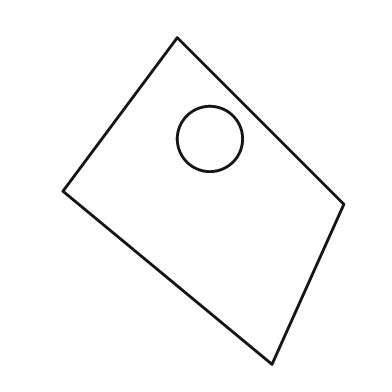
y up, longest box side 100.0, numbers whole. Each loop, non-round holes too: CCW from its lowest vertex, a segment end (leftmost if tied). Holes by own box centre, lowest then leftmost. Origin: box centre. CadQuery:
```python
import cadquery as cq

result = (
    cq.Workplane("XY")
    .moveTo(21.0, -50.0)
    .lineTo(43.0, -1.0)
    .lineTo(-8.0, 50.0)
    .lineTo(-43.0, 3.0)
    .close()
    .moveTo(2.0, 19.0)
    .circle(10.0)
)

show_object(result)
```